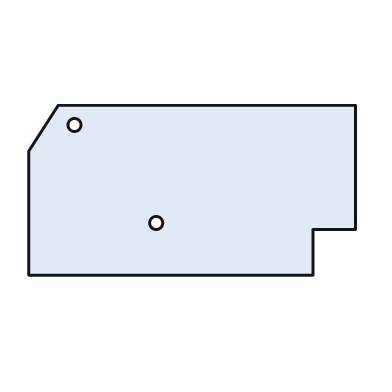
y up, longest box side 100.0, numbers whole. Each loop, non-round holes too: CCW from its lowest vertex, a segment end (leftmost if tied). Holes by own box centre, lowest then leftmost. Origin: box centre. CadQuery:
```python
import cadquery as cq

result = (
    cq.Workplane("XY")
    .moveTo(-50.0, -26.0)
    .lineTo(37.0, -26.0)
    .lineTo(37.0, -12.0)
    .lineTo(50.0, -12.0)
    .lineTo(50.0, 26.0)
    .lineTo(-41.0, 26.0)
    .lineTo(-50.0, 12.0)
    .close()
    .moveTo(-11.0, -10.0)
    .circle(2.0)
    .moveTo(-36.0, 20.0)
    .circle(2.0)
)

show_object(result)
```